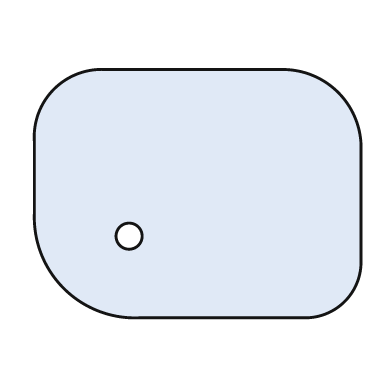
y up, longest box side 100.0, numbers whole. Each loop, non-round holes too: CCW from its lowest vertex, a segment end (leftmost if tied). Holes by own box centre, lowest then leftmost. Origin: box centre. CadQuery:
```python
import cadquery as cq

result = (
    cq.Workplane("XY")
    .moveTo(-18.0, -38.0)
    .lineTo(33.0, -38.0)
    .threePointArc((45.0, -33.0), (50.0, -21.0))
    .lineTo(50.0, 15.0)
    .threePointArc((43.0, 31.0), (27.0, 38.0))
    .lineTo(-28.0, 38.0)
    .threePointArc((-44.0, 32.0), (-50.0, 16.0))
    .lineTo(-50.0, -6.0)
    .threePointArc((-41.0, -29.0), (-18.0, -38.0))
    .close()
    .moveTo(-21.0, -13.0)
    .circle(4.0)
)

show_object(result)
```